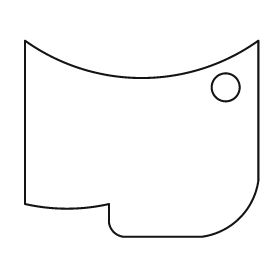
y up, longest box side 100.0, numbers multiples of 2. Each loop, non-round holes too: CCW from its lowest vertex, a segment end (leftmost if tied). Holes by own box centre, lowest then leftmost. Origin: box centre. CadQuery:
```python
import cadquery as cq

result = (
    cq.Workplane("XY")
    .moveTo(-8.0, -42.0)
    .lineTo(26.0, -42.0)
    .threePointArc((42.0, -34.0), (50.0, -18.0))
    .lineTo(50.0, 42.0)
    .threePointArc((0.0, 26.0), (-50.0, 42.0))
    .lineTo(-50.0, -28.0)
    .threePointArc((-32.0, -30.0), (-14.0, -28.0))
    .lineTo(-14.0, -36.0)
    .threePointArc((-12.0, -40.0), (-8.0, -42.0))
    .close()
    .moveTo(36.0, 22.0)
    .circle(6.0)
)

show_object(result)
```